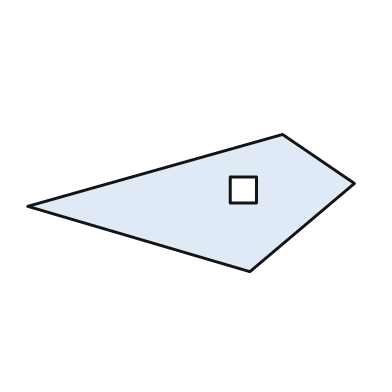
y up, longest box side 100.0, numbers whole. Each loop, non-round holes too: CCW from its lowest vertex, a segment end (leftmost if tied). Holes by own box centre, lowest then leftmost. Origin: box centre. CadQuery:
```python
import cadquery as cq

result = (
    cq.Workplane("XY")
    .moveTo(18.0, -21.0)
    .lineTo(50.0, 6.0)
    .lineTo(28.0, 21.0)
    .lineTo(-50.0, -1.0)
    .close()
    .moveTo(12.0, 0.0)
    .lineTo(20.0, 0.0)
    .lineTo(20.0, 8.0)
    .lineTo(12.0, 8.0)
    .close()
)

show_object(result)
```